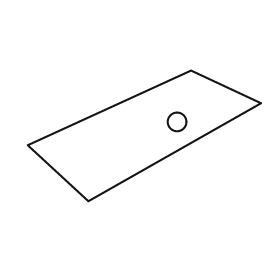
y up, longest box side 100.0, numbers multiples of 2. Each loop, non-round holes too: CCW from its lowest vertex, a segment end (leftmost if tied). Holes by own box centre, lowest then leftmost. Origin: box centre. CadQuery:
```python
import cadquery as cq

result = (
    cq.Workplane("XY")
    .moveTo(-24.0, -28.0)
    .lineTo(50.0, 14.0)
    .lineTo(20.0, 28.0)
    .lineTo(-50.0, -4.0)
    .close()
    .moveTo(14.0, 6.0)
    .circle(4.0)
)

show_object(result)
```